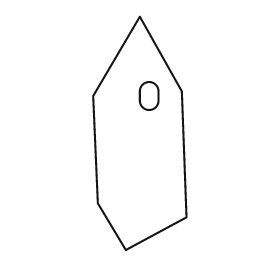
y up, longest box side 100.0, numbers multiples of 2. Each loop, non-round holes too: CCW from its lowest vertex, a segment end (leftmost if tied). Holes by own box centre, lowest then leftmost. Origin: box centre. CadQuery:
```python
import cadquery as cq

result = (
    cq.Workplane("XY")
    .moveTo(-6.0, -50.0)
    .lineTo(20.0, -36.0)
    .lineTo(18.0, 18.0)
    .lineTo(0.0, 50.0)
    .lineTo(-20.0, 16.0)
    .lineTo(-18.0, -30.0)
    .close()
    .moveTo(0.0, 14.0)
    .threePointArc((4.0, 10.0), (8.0, 14.0))
    .lineTo(8.0, 18.0)
    .threePointArc((4.0, 22.0), (0.0, 18.0))
    .close()
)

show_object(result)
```